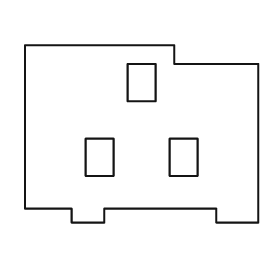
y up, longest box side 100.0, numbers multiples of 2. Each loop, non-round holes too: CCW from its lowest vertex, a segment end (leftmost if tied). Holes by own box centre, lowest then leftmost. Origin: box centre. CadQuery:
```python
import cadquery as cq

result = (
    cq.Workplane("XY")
    .moveTo(-30.0, -38.0)
    .lineTo(-16.0, -38.0)
    .lineTo(-16.0, -32.0)
    .lineTo(32.0, -32.0)
    .lineTo(32.0, -38.0)
    .lineTo(50.0, -38.0)
    .lineTo(50.0, 30.0)
    .lineTo(14.0, 30.0)
    .lineTo(14.0, 38.0)
    .lineTo(-50.0, 38.0)
    .lineTo(-50.0, -32.0)
    .lineTo(-30.0, -32.0)
    .close()
    .moveTo(-24.0, -18.0)
    .lineTo(-12.0, -18.0)
    .lineTo(-12.0, -2.0)
    .lineTo(-24.0, -2.0)
    .close()
    .moveTo(12.0, -18.0)
    .lineTo(24.0, -18.0)
    .lineTo(24.0, -2.0)
    .lineTo(12.0, -2.0)
    .close()
    .moveTo(-6.0, 14.0)
    .lineTo(6.0, 14.0)
    .lineTo(6.0, 30.0)
    .lineTo(-6.0, 30.0)
    .close()
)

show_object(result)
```